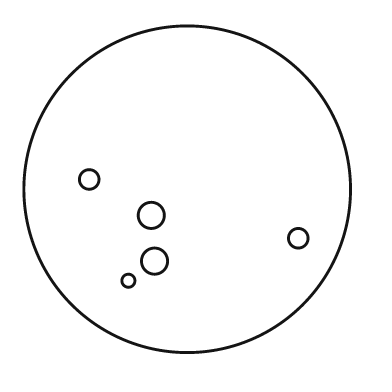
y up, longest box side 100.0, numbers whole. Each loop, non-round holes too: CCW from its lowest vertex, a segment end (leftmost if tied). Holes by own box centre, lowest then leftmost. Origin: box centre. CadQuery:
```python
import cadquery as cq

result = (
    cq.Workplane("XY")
    .moveTo(0.0, 0.0)
    .circle(50.0)
    .moveTo(-18.0, -28.0)
    .circle(2.0)
    .moveTo(-10.0, -22.0)
    .circle(4.0)
    .moveTo(34.0, -15.0)
    .circle(3.0)
    .moveTo(-11.0, -8.0)
    .circle(4.0)
    .moveTo(-30.0, 3.0)
    .circle(3.0)
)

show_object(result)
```